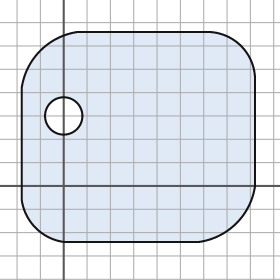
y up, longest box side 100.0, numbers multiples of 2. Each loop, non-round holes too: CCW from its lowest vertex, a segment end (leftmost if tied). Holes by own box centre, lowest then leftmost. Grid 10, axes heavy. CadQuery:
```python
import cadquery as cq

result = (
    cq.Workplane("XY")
    .moveTo(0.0, -24.0)
    .lineTo(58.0, -24.0)
    .threePointArc((74.0, -16.0), (82.0, 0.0))
    .lineTo(82.0, 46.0)
    .threePointArc((76.0, 60.0), (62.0, 66.0))
    .lineTo(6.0, 66.0)
    .threePointArc((-10.0, 58.0), (-18.0, 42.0))
    .lineTo(-18.0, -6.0)
    .threePointArc((-12.0, -18.0), (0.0, -24.0))
    .close()
    .moveTo(0.0, 30.0)
    .circle(8.0)
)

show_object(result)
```